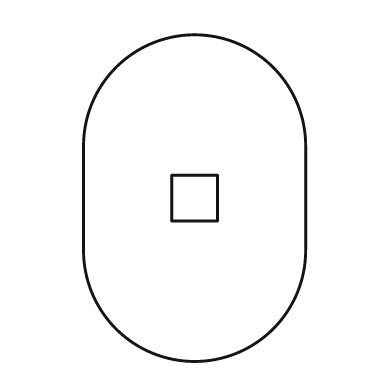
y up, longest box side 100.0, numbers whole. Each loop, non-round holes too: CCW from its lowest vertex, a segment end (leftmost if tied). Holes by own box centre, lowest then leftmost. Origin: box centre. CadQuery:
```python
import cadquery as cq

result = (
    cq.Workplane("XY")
    .moveTo(-34.0, -16.0)
    .threePointArc((0.0, -50.0), (34.0, -16.0))
    .lineTo(34.0, 16.0)
    .threePointArc((0.0, 50.0), (-34.0, 16.0))
    .close()
    .moveTo(-7.0, -7.0)
    .lineTo(7.0, -7.0)
    .lineTo(7.0, 7.0)
    .lineTo(-7.0, 7.0)
    .close()
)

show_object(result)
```